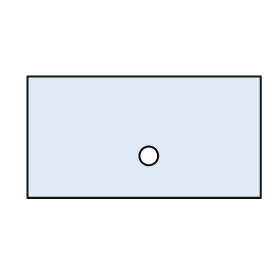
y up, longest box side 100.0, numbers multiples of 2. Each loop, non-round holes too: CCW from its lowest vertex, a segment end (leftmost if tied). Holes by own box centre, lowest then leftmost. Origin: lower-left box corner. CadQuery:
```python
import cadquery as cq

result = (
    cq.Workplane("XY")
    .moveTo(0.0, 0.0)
    .lineTo(100.0, 0.0)
    .lineTo(100.0, 52.0)
    .lineTo(0.0, 52.0)
    .close()
    .moveTo(52.0, 18.0)
    .circle(4.0)
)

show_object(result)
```